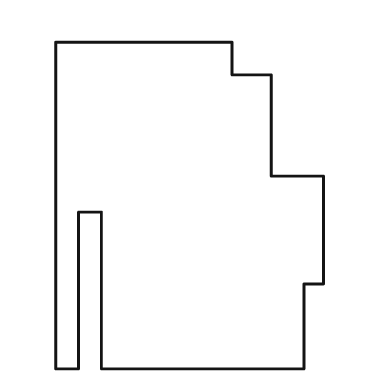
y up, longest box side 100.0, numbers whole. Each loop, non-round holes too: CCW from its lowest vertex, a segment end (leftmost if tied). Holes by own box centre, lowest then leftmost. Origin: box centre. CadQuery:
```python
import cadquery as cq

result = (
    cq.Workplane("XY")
    .moveTo(-41.0, -50.0)
    .lineTo(-34.0, -50.0)
    .lineTo(-34.0, -2.0)
    .lineTo(-27.0, -2.0)
    .lineTo(-27.0, -50.0)
    .lineTo(35.0, -50.0)
    .lineTo(35.0, -24.0)
    .lineTo(41.0, -24.0)
    .lineTo(41.0, 9.0)
    .lineTo(25.0, 9.0)
    .lineTo(25.0, 40.0)
    .lineTo(13.0, 40.0)
    .lineTo(13.0, 50.0)
    .lineTo(-41.0, 50.0)
    .close()
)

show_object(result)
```